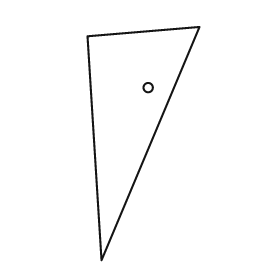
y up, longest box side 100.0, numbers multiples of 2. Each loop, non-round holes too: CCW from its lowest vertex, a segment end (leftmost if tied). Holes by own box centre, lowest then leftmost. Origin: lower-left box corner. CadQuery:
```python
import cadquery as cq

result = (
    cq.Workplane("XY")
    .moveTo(6.0, 0.0)
    .lineTo(48.0, 100.0)
    .lineTo(0.0, 96.0)
    .close()
    .moveTo(26.0, 74.0)
    .circle(2.0)
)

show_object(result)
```